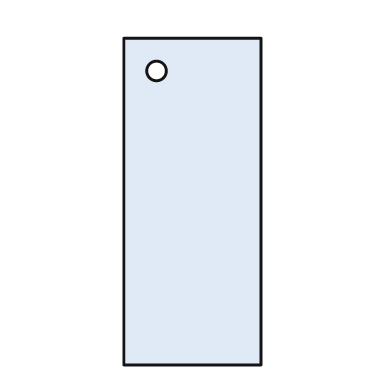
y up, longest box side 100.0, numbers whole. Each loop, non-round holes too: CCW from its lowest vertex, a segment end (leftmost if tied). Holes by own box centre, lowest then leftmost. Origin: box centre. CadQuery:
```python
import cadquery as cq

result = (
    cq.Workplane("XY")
    .moveTo(-21.0, -50.0)
    .lineTo(21.0, -50.0)
    .lineTo(21.0, 50.0)
    .lineTo(-21.0, 50.0)
    .close()
    .moveTo(-11.0, 40.0)
    .circle(3.0)
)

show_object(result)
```